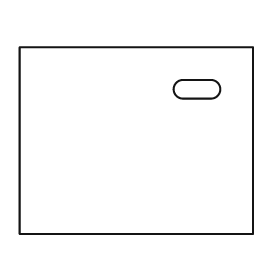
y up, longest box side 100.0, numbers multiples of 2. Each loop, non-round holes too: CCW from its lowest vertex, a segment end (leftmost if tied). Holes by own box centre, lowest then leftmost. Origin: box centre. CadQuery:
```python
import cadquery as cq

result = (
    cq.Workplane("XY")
    .moveTo(-50.0, -40.0)
    .lineTo(50.0, -40.0)
    .lineTo(50.0, 40.0)
    .lineTo(-50.0, 40.0)
    .close()
    .moveTo(20.0, 18.0)
    .lineTo(32.0, 18.0)
    .threePointArc((36.0, 22.0), (32.0, 26.0))
    .lineTo(20.0, 26.0)
    .threePointArc((16.0, 22.0), (20.0, 18.0))
    .close()
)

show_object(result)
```